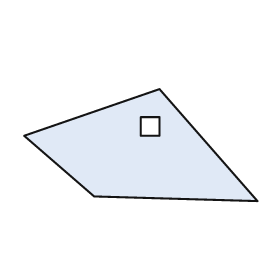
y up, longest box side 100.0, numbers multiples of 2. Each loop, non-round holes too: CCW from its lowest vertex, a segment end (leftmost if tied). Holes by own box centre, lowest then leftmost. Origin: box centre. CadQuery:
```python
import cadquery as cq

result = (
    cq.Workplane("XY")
    .moveTo(50.0, -24.0)
    .lineTo(8.0, 24.0)
    .lineTo(-50.0, 4.0)
    .lineTo(-20.0, -22.0)
    .close()
    .moveTo(0.0, 4.0)
    .lineTo(8.0, 4.0)
    .lineTo(8.0, 12.0)
    .lineTo(0.0, 12.0)
    .close()
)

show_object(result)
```